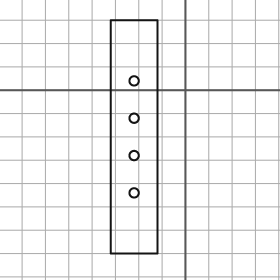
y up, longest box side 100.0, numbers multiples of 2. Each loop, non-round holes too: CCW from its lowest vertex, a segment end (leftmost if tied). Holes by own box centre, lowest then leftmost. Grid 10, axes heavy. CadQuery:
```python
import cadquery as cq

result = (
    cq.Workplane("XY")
    .moveTo(-32.0, -70.0)
    .lineTo(-12.0, -70.0)
    .lineTo(-12.0, 30.0)
    .lineTo(-32.0, 30.0)
    .close()
    .moveTo(-22.0, -44.0)
    .circle(2.0)
    .moveTo(-22.0, -28.0)
    .circle(2.0)
    .moveTo(-22.0, -12.0)
    .circle(2.0)
    .moveTo(-22.0, 4.0)
    .circle(2.0)
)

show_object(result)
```